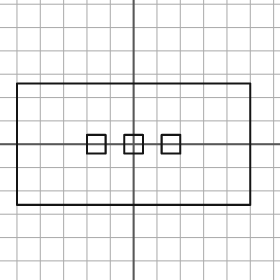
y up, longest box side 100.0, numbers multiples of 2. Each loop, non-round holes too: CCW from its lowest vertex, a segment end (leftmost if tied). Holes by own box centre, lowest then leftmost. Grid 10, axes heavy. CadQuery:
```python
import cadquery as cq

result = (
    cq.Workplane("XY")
    .moveTo(-50.0, -26.0)
    .lineTo(50.0, -26.0)
    .lineTo(50.0, 26.0)
    .lineTo(-50.0, 26.0)
    .close()
    .moveTo(-20.0, -4.0)
    .lineTo(-12.0, -4.0)
    .lineTo(-12.0, 4.0)
    .lineTo(-20.0, 4.0)
    .close()
    .moveTo(-4.0, -4.0)
    .lineTo(4.0, -4.0)
    .lineTo(4.0, 4.0)
    .lineTo(-4.0, 4.0)
    .close()
    .moveTo(12.0, -4.0)
    .lineTo(20.0, -4.0)
    .lineTo(20.0, 4.0)
    .lineTo(12.0, 4.0)
    .close()
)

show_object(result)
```